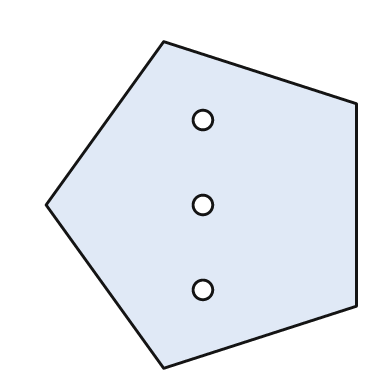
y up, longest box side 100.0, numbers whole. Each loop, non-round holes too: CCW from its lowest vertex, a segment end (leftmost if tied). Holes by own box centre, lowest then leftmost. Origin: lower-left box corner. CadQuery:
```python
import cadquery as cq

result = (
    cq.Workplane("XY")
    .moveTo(36.0, 0.0)
    .lineTo(95.0, 19.0)
    .lineTo(95.0, 81.0)
    .lineTo(36.0, 100.0)
    .lineTo(0.0, 50.0)
    .close()
    .moveTo(48.0, 24.0)
    .circle(3.0)
    .moveTo(48.0, 50.0)
    .circle(3.0)
    .moveTo(48.0, 76.0)
    .circle(3.0)
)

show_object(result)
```